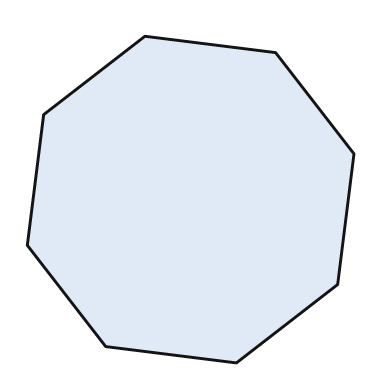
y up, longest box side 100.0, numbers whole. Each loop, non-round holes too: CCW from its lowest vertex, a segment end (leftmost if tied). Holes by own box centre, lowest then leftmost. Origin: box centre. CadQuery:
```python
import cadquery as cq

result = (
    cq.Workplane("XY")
    .moveTo(14.0, -50.0)
    .lineTo(45.0, -26.0)
    .lineTo(50.0, 14.0)
    .lineTo(26.0, 45.0)
    .lineTo(-14.0, 50.0)
    .lineTo(-45.0, 26.0)
    .lineTo(-50.0, -14.0)
    .lineTo(-26.0, -45.0)
    .close()
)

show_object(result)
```